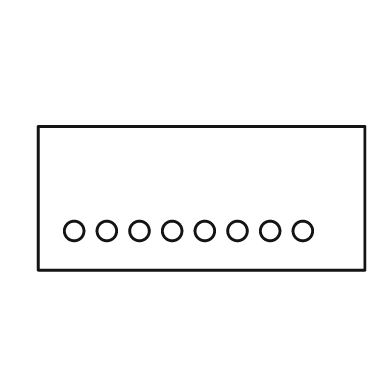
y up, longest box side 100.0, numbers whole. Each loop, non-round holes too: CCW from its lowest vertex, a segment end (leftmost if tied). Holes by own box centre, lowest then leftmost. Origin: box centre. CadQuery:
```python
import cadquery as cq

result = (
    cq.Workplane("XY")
    .moveTo(-50.0, -22.0)
    .lineTo(50.0, -22.0)
    .lineTo(50.0, 22.0)
    .lineTo(-50.0, 22.0)
    .close()
    .moveTo(-39.0, -10.0)
    .circle(3.0)
    .moveTo(-29.0, -10.0)
    .circle(3.0)
    .moveTo(-19.0, -10.0)
    .circle(3.0)
    .moveTo(-9.0, -10.0)
    .circle(3.0)
    .moveTo(1.0, -10.0)
    .circle(3.0)
    .moveTo(11.0, -10.0)
    .circle(3.0)
    .moveTo(21.0, -10.0)
    .circle(3.0)
    .moveTo(31.0, -10.0)
    .circle(3.0)
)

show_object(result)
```